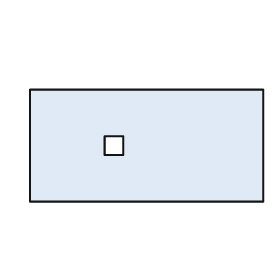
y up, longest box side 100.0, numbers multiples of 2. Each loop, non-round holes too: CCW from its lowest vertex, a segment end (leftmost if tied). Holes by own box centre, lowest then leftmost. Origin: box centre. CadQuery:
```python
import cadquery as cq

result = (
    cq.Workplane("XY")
    .moveTo(-50.0, -24.0)
    .lineTo(50.0, -24.0)
    .lineTo(50.0, 24.0)
    .lineTo(-50.0, 24.0)
    .close()
    .moveTo(-18.0, -4.0)
    .lineTo(-10.0, -4.0)
    .lineTo(-10.0, 4.0)
    .lineTo(-18.0, 4.0)
    .close()
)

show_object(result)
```